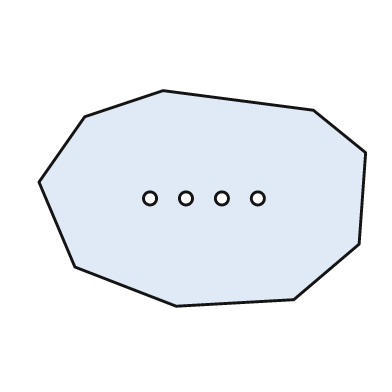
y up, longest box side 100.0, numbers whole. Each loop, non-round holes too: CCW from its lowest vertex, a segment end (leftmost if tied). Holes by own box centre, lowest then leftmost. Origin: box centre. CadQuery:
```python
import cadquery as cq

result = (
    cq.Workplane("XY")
    .moveTo(-8.0, -33.0)
    .lineTo(28.0, -31.0)
    .lineTo(48.0, -14.0)
    .lineTo(50.0, 14.0)
    .lineTo(34.0, 27.0)
    .lineTo(-12.0, 33.0)
    .lineTo(-36.0, 25.0)
    .lineTo(-50.0, 5.0)
    .lineTo(-39.0, -21.0)
    .close()
    .moveTo(-16.0, 0.0)
    .circle(2.0)
    .moveTo(-5.0, 0.0)
    .circle(2.0)
    .moveTo(6.0, 0.0)
    .circle(2.0)
    .moveTo(17.0, 0.0)
    .circle(2.0)
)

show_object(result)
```